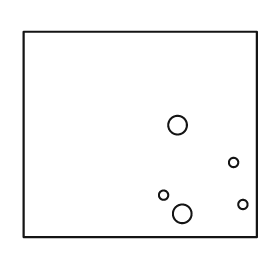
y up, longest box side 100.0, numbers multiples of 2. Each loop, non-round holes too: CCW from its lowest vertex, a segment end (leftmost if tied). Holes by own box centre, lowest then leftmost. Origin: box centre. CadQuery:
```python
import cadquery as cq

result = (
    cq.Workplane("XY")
    .moveTo(-50.0, -44.0)
    .lineTo(50.0, -44.0)
    .lineTo(50.0, 44.0)
    .lineTo(-50.0, 44.0)
    .close()
    .moveTo(18.0, -34.0)
    .circle(4.0)
    .moveTo(44.0, -30.0)
    .circle(2.0)
    .moveTo(10.0, -26.0)
    .circle(2.0)
    .moveTo(40.0, -12.0)
    .circle(2.0)
    .moveTo(16.0, 4.0)
    .circle(4.0)
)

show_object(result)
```